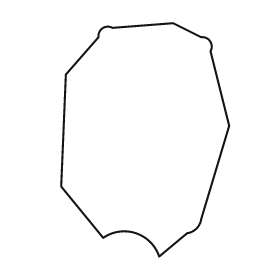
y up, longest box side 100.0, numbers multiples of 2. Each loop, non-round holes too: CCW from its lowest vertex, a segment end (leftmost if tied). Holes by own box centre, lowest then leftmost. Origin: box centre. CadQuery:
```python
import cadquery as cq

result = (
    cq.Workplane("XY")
    .moveTo(6.0, -50.0)
    .lineTo(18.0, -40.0)
    .threePointArc((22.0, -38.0), (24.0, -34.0))
    .lineTo(36.0, 6.0)
    .lineTo(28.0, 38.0)
    .threePointArc((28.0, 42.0), (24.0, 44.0))
    .lineTo(12.0, 50.0)
    .lineTo(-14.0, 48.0)
    .threePointArc((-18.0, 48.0), (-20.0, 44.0))
    .lineTo(-34.0, 28.0)
    .lineTo(-36.0, -20.0)
    .lineTo(-18.0, -42.0)
    .threePointArc((-4.0, -40.0), (6.0, -50.0))
    .close()
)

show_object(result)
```